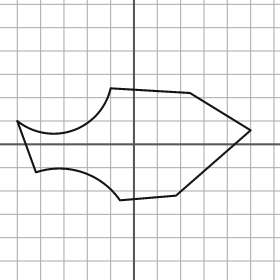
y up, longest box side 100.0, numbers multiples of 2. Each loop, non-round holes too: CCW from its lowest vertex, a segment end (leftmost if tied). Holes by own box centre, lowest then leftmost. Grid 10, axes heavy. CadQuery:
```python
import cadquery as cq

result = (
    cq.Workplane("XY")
    .moveTo(-6.0, -24.0)
    .lineTo(18.0, -22.0)
    .lineTo(50.0, 6.0)
    .lineTo(24.0, 22.0)
    .lineTo(-10.0, 24.0)
    .threePointArc((-26.0, 6.0), (-50.0, 10.0))
    .lineTo(-42.0, -12.0)
    .threePointArc((-22.0, -12.0), (-6.0, -24.0))
    .close()
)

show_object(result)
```